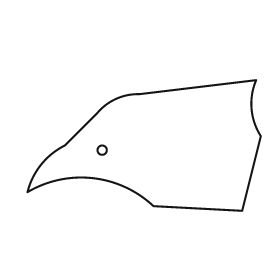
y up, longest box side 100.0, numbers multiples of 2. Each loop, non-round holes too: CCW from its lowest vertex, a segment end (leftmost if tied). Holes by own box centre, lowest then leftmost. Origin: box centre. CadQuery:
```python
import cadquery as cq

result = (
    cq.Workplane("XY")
    .moveTo(42.0, -28.0)
    .lineTo(50.0, 4.0)
    .threePointArc((46.0, 16.0), (48.0, 28.0))
    .lineTo(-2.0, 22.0)
    .threePointArc((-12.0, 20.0), (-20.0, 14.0))
    .lineTo(-34.0, 0.0)
    .threePointArc((-44.0, -8.0), (-50.0, -20.0))
    .threePointArc((-22.0, -14.0), (4.0, -26.0))
    .close()
    .moveTo(-18.0, -2.0)
    .circle(2.0)
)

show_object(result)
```